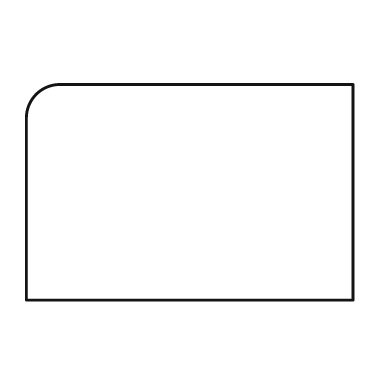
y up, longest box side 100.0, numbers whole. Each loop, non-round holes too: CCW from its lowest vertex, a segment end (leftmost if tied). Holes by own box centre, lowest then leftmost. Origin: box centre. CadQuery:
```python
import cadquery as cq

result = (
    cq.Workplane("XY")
    .moveTo(-50.0, -33.0)
    .lineTo(50.0, -33.0)
    .lineTo(50.0, 33.0)
    .lineTo(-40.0, 33.0)
    .threePointArc((-47.0, 30.0), (-50.0, 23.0))
    .close()
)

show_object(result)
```